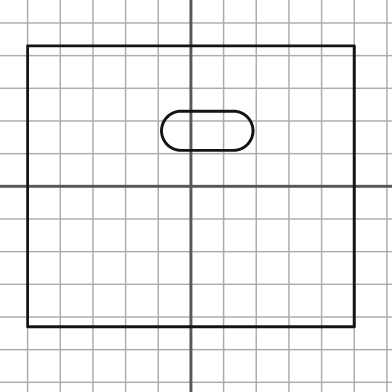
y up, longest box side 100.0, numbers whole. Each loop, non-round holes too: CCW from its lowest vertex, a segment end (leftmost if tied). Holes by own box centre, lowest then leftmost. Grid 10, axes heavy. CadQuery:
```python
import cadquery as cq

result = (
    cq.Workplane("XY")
    .moveTo(-50.0, -43.0)
    .lineTo(50.0, -43.0)
    .lineTo(50.0, 43.0)
    .lineTo(-50.0, 43.0)
    .close()
    .moveTo(-3.0, 11.0)
    .lineTo(13.0, 11.0)
    .threePointArc((19.0, 17.0), (13.0, 23.0))
    .lineTo(-3.0, 23.0)
    .threePointArc((-9.0, 17.0), (-3.0, 11.0))
    .close()
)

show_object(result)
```